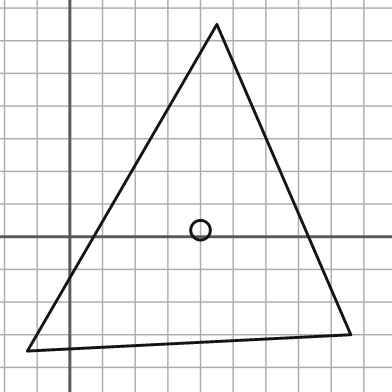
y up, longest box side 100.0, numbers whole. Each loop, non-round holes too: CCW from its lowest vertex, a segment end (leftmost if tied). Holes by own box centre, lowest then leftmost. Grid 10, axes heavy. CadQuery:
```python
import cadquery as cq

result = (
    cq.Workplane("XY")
    .moveTo(-13.0, -35.0)
    .lineTo(86.0, -30.0)
    .lineTo(45.0, 65.0)
    .close()
    .moveTo(40.0, 2.0)
    .circle(3.0)
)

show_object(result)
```